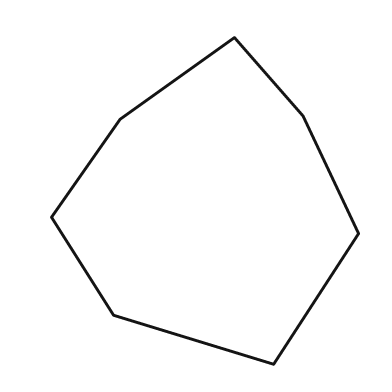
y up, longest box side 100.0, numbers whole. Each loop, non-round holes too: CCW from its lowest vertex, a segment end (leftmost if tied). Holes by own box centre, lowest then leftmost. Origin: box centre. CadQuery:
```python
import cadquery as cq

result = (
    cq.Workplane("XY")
    .moveTo(21.0, -50.0)
    .lineTo(47.0, -10.0)
    .lineTo(30.0, 26.0)
    .lineTo(9.0, 50.0)
    .lineTo(-26.0, 25.0)
    .lineTo(-47.0, -5.0)
    .lineTo(-28.0, -35.0)
    .close()
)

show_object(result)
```